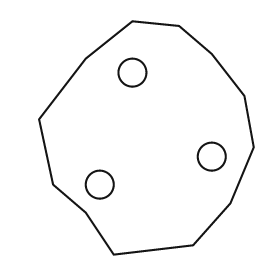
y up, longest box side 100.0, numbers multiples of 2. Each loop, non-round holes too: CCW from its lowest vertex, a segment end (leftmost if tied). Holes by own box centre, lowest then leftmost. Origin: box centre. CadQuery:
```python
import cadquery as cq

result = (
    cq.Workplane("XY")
    .moveTo(-14.0, -50.0)
    .lineTo(20.0, -46.0)
    .lineTo(36.0, -28.0)
    .lineTo(46.0, -4.0)
    .lineTo(42.0, 18.0)
    .lineTo(28.0, 36.0)
    .lineTo(14.0, 48.0)
    .lineTo(-6.0, 50.0)
    .lineTo(-26.0, 34.0)
    .lineTo(-46.0, 8.0)
    .lineTo(-40.0, -20.0)
    .lineTo(-26.0, -32.0)
    .close()
    .moveTo(-20.0, -20.0)
    .circle(6.0)
    .moveTo(28.0, -8.0)
    .circle(6.0)
    .moveTo(-6.0, 28.0)
    .circle(6.0)
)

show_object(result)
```